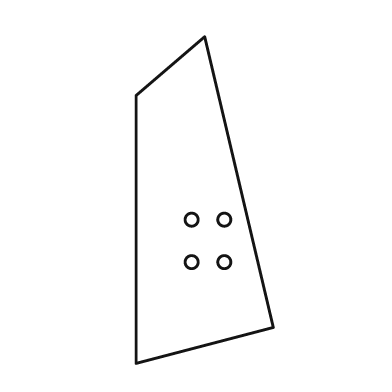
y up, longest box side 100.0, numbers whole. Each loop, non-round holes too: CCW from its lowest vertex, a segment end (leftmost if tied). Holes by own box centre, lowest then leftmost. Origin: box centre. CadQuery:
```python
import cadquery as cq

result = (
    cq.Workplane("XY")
    .moveTo(-21.0, -50.0)
    .lineTo(21.0, -39.0)
    .lineTo(0.0, 50.0)
    .lineTo(-21.0, 32.0)
    .close()
    .moveTo(-4.0, -19.0)
    .circle(2.0)
    .moveTo(6.0, -19.0)
    .circle(2.0)
    .moveTo(-4.0, -6.0)
    .circle(2.0)
    .moveTo(6.0, -6.0)
    .circle(2.0)
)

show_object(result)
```